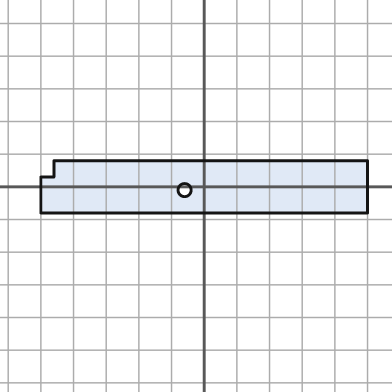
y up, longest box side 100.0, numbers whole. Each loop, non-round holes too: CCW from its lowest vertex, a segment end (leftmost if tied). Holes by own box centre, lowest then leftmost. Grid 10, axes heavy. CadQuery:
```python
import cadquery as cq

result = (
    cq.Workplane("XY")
    .moveTo(-50.0, -8.0)
    .lineTo(50.0, -8.0)
    .lineTo(50.0, 8.0)
    .lineTo(-46.0, 8.0)
    .lineTo(-46.0, 3.0)
    .lineTo(-50.0, 3.0)
    .close()
    .moveTo(-6.0, -1.0)
    .circle(2.0)
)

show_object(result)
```